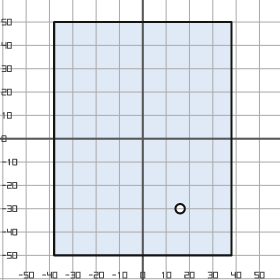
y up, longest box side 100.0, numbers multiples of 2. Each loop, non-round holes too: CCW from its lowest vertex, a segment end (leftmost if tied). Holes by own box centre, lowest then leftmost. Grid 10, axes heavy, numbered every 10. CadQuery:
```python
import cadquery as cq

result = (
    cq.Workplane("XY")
    .moveTo(-38.0, -50.0)
    .lineTo(38.0, -50.0)
    .lineTo(38.0, 50.0)
    .lineTo(-38.0, 50.0)
    .close()
    .moveTo(16.0, -30.0)
    .circle(2.0)
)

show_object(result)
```